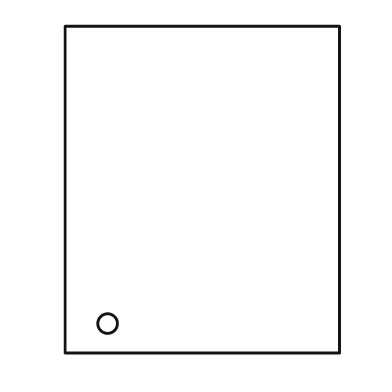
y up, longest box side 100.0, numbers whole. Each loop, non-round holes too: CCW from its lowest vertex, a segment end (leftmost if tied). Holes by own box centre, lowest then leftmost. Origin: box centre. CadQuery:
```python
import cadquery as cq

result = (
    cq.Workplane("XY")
    .moveTo(-42.0, -50.0)
    .lineTo(42.0, -50.0)
    .lineTo(42.0, 50.0)
    .lineTo(-42.0, 50.0)
    .close()
    .moveTo(-29.0, -41.0)
    .circle(3.0)
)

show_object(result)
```